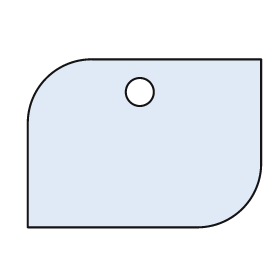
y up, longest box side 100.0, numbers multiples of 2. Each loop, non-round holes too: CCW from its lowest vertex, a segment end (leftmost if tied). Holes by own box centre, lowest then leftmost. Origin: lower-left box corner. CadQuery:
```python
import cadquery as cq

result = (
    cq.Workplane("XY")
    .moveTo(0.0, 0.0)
    .lineTo(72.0, 0.0)
    .threePointArc((92.0, 8.0), (100.0, 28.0))
    .lineTo(100.0, 72.0)
    .lineTo(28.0, 72.0)
    .threePointArc((8.0, 64.0), (0.0, 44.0))
    .close()
    .moveTo(48.0, 58.0)
    .circle(6.0)
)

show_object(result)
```